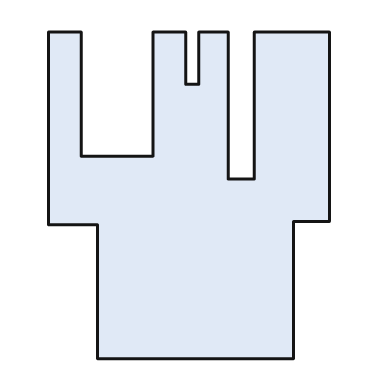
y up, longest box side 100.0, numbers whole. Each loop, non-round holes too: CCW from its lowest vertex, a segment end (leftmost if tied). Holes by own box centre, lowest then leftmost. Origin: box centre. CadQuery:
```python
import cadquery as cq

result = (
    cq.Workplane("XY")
    .moveTo(-28.0, -50.0)
    .lineTo(32.0, -50.0)
    .lineTo(32.0, -8.0)
    .lineTo(43.0, -8.0)
    .lineTo(43.0, 50.0)
    .lineTo(20.0, 50.0)
    .lineTo(20.0, 5.0)
    .lineTo(12.0, 5.0)
    .lineTo(12.0, 50.0)
    .lineTo(3.0, 50.0)
    .lineTo(3.0, 34.0)
    .lineTo(-1.0, 34.0)
    .lineTo(-1.0, 50.0)
    .lineTo(-11.0, 50.0)
    .lineTo(-11.0, 12.0)
    .lineTo(-33.0, 12.0)
    .lineTo(-33.0, 50.0)
    .lineTo(-43.0, 50.0)
    .lineTo(-43.0, -9.0)
    .lineTo(-28.0, -9.0)
    .close()
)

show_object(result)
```